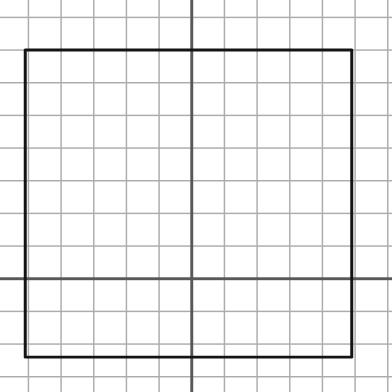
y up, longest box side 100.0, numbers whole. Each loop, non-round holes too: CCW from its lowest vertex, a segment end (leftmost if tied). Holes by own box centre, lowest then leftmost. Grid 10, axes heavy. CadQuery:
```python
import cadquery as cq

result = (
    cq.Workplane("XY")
    .moveTo(-51.0, -24.0)
    .lineTo(49.0, -24.0)
    .lineTo(49.0, 70.0)
    .lineTo(-51.0, 70.0)
    .close()
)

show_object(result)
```